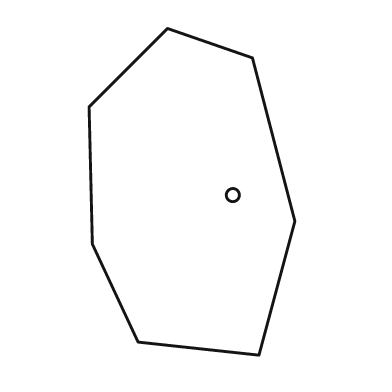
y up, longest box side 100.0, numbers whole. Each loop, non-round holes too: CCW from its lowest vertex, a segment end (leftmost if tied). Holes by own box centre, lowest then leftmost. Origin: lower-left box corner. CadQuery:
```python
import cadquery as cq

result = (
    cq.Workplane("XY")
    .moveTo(52.0, 0.0)
    .lineTo(63.0, 41.0)
    .lineTo(50.0, 91.0)
    .lineTo(24.0, 100.0)
    .lineTo(0.0, 76.0)
    .lineTo(1.0, 34.0)
    .lineTo(15.0, 4.0)
    .close()
    .moveTo(44.0, 49.0)
    .circle(2.0)
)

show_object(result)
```